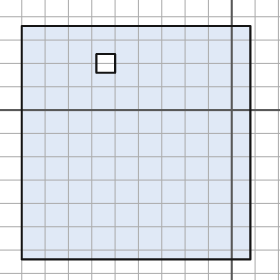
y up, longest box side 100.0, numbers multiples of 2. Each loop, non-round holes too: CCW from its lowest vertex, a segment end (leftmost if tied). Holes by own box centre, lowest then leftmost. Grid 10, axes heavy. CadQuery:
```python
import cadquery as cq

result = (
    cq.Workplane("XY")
    .moveTo(-90.0, -64.0)
    .lineTo(8.0, -64.0)
    .lineTo(8.0, 36.0)
    .lineTo(-90.0, 36.0)
    .close()
    .moveTo(-58.0, 16.0)
    .lineTo(-50.0, 16.0)
    .lineTo(-50.0, 24.0)
    .lineTo(-58.0, 24.0)
    .close()
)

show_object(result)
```